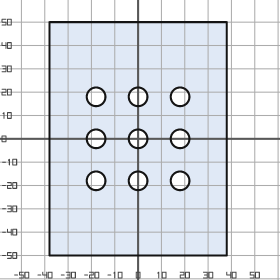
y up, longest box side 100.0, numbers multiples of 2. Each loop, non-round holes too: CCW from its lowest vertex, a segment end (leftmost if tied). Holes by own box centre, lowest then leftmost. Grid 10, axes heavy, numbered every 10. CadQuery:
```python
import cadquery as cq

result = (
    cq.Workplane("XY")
    .moveTo(-38.0, -50.0)
    .lineTo(38.0, -50.0)
    .lineTo(38.0, 50.0)
    .lineTo(-38.0, 50.0)
    .close()
    .moveTo(-18.0, -18.0)
    .circle(4.0)
    .moveTo(0.0, -18.0)
    .circle(4.0)
    .moveTo(18.0, -18.0)
    .circle(4.0)
    .moveTo(-18.0, 0.0)
    .circle(4.0)
    .moveTo(0.0, 0.0)
    .circle(4.0)
    .moveTo(18.0, 0.0)
    .circle(4.0)
    .moveTo(-18.0, 18.0)
    .circle(4.0)
    .moveTo(0.0, 18.0)
    .circle(4.0)
    .moveTo(18.0, 18.0)
    .circle(4.0)
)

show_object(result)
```